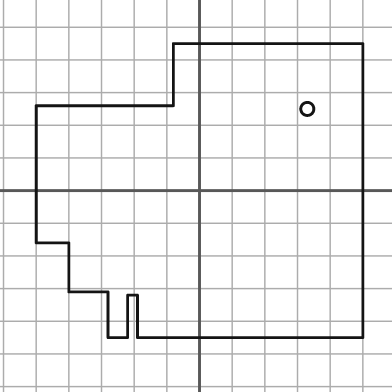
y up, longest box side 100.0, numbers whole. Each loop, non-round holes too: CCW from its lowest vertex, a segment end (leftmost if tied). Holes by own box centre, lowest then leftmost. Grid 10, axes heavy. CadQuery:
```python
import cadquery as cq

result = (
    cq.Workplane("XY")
    .moveTo(-28.0, -45.0)
    .lineTo(-22.0, -45.0)
    .lineTo(-22.0, -32.0)
    .lineTo(-19.0, -32.0)
    .lineTo(-19.0, -45.0)
    .lineTo(50.0, -45.0)
    .lineTo(50.0, 45.0)
    .lineTo(-8.0, 45.0)
    .lineTo(-8.0, 26.0)
    .lineTo(-50.0, 26.0)
    .lineTo(-50.0, -16.0)
    .lineTo(-40.0, -16.0)
    .lineTo(-40.0, -31.0)
    .lineTo(-28.0, -31.0)
    .close()
    .moveTo(33.0, 25.0)
    .circle(2.0)
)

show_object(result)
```